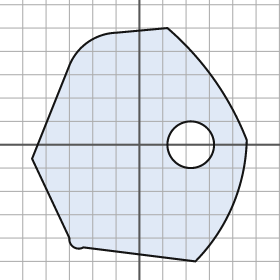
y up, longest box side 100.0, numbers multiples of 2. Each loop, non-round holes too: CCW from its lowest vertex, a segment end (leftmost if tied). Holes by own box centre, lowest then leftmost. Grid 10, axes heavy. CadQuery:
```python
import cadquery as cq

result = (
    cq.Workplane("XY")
    .moveTo(24.0, -50.0)
    .threePointArc((40.0, -26.0), (46.0, 2.0))
    .threePointArc((32.0, 28.0), (12.0, 50.0))
    .lineTo(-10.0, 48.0)
    .threePointArc((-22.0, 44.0), (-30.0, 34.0))
    .lineTo(-46.0, -6.0)
    .lineTo(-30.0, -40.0)
    .threePointArc((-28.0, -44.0), (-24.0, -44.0))
    .close()
    .moveTo(22.0, 0.0)
    .circle(10.0)
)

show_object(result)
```